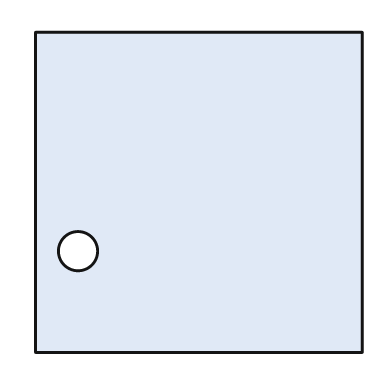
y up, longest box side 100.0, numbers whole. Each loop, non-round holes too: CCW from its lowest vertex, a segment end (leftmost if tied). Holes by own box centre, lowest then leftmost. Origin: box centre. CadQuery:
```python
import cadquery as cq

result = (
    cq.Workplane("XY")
    .moveTo(-50.0, -49.0)
    .lineTo(50.0, -49.0)
    .lineTo(50.0, 49.0)
    .lineTo(-50.0, 49.0)
    .close()
    .moveTo(-37.0, -18.0)
    .circle(6.0)
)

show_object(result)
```